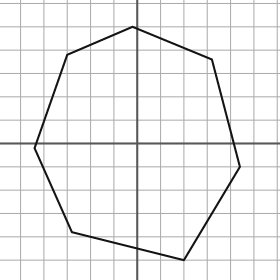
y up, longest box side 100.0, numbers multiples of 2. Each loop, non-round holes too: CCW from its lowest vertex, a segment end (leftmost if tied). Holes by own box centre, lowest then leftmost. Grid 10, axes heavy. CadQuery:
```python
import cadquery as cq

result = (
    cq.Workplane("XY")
    .moveTo(20.0, -50.0)
    .lineTo(44.0, -10.0)
    .lineTo(32.0, 36.0)
    .lineTo(-2.0, 50.0)
    .lineTo(-30.0, 38.0)
    .lineTo(-44.0, -2.0)
    .lineTo(-28.0, -38.0)
    .close()
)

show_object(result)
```